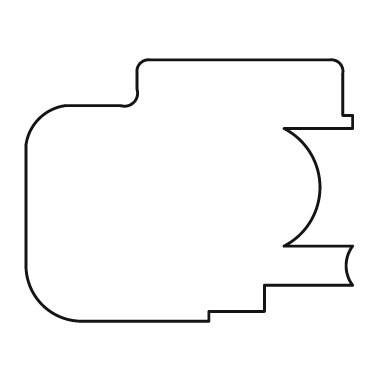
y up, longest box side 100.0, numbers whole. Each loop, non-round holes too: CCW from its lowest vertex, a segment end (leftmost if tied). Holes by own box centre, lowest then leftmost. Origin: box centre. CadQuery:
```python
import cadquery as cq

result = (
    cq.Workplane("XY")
    .moveTo(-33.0, -40.0)
    .lineTo(6.0, -40.0)
    .lineTo(6.0, -37.0)
    .lineTo(23.0, -37.0)
    .lineTo(23.0, -29.0)
    .lineTo(50.0, -29.0)
    .threePointArc((48.0, -23.0), (50.0, -17.0))
    .lineTo(29.0, -17.0)
    .threePointArc((40.0, 1.0), (29.0, 19.0))
    .lineTo(50.0, 19.0)
    .lineTo(50.0, 23.0)
    .lineTo(47.0, 23.0)
    .lineTo(47.0, 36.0)
    .threePointArc((46.0, 39.0), (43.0, 40.0))
    .lineTo(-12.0, 40.0)
    .threePointArc((-15.0, 39.0), (-16.0, 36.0))
    .lineTo(-16.0, 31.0)
    .threePointArc((-17.0, 27.0), (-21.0, 26.0))
    .lineTo(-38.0, 26.0)
    .threePointArc((-46.0, 22.0), (-50.0, 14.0))
    .lineTo(-50.0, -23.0)
    .threePointArc((-45.0, -35.0), (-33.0, -40.0))
    .close()
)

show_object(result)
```